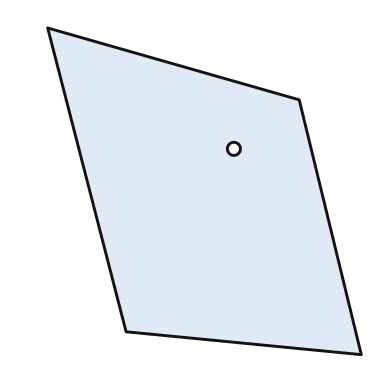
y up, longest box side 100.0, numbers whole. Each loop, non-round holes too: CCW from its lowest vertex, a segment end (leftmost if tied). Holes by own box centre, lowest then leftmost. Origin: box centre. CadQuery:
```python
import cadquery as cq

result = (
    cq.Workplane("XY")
    .moveTo(48.0, -50.0)
    .lineTo(29.0, 28.0)
    .lineTo(-48.0, 50.0)
    .lineTo(-24.0, -43.0)
    .close()
    .moveTo(9.0, 13.0)
    .circle(2.0)
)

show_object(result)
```